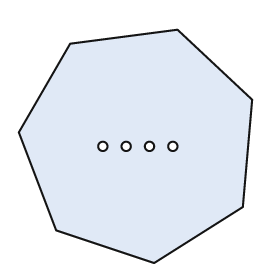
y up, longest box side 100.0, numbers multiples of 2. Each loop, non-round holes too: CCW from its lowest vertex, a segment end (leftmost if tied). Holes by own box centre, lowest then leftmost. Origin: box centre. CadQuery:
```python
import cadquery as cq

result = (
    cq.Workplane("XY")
    .moveTo(8.0, -50.0)
    .lineTo(46.0, -26.0)
    .lineTo(50.0, 20.0)
    .lineTo(18.0, 50.0)
    .lineTo(-28.0, 44.0)
    .lineTo(-50.0, 6.0)
    .lineTo(-34.0, -36.0)
    .close()
    .moveTo(-14.0, 0.0)
    .circle(2.0)
    .moveTo(-4.0, 0.0)
    .circle(2.0)
    .moveTo(6.0, 0.0)
    .circle(2.0)
    .moveTo(16.0, 0.0)
    .circle(2.0)
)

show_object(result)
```